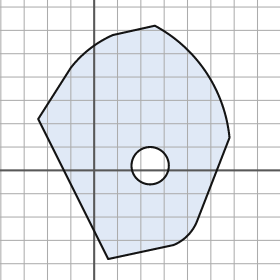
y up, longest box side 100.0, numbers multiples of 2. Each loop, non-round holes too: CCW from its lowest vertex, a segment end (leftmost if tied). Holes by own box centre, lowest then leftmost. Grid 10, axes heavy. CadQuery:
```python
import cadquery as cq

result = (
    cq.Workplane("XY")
    .moveTo(6.0, -38.0)
    .lineTo(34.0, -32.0)
    .threePointArc((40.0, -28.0), (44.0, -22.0))
    .lineTo(58.0, 14.0)
    .threePointArc((48.0, 42.0), (26.0, 62.0))
    .lineTo(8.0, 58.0)
    .threePointArc((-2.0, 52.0), (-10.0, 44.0))
    .lineTo(-24.0, 22.0)
    .close()
    .moveTo(24.0, 2.0)
    .circle(8.0)
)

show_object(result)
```